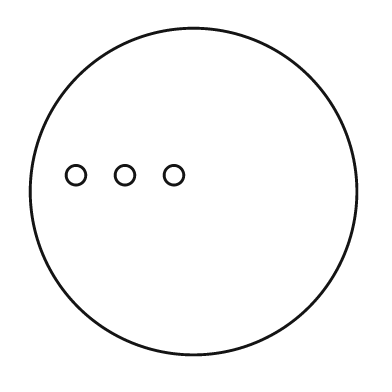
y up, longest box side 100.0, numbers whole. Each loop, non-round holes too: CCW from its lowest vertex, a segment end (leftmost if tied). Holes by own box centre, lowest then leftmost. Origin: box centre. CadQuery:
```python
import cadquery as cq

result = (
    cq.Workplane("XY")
    .moveTo(0.0, 0.0)
    .circle(50.0)
    .moveTo(-36.0, 5.0)
    .circle(3.0)
    .moveTo(-21.0, 5.0)
    .circle(3.0)
    .moveTo(-6.0, 5.0)
    .circle(3.0)
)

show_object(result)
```